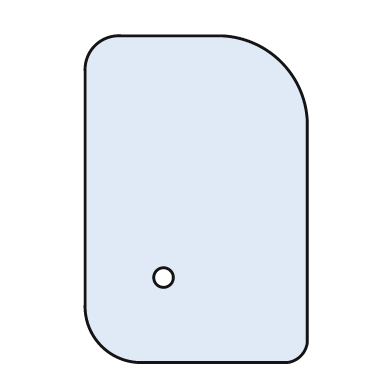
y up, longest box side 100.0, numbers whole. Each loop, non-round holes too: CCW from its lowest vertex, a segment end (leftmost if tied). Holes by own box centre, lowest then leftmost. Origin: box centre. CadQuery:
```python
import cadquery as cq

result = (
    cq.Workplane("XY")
    .moveTo(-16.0, -50.0)
    .lineTo(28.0, -50.0)
    .threePointArc((32.0, -48.0), (34.0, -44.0))
    .lineTo(34.0, 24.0)
    .threePointArc((26.0, 42.0), (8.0, 50.0))
    .lineTo(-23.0, 50.0)
    .threePointArc((-31.0, 47.0), (-34.0, 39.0))
    .lineTo(-34.0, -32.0)
    .threePointArc((-29.0, -45.0), (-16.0, -50.0))
    .close()
    .moveTo(-10.0, -24.0)
    .circle(3.0)
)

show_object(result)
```